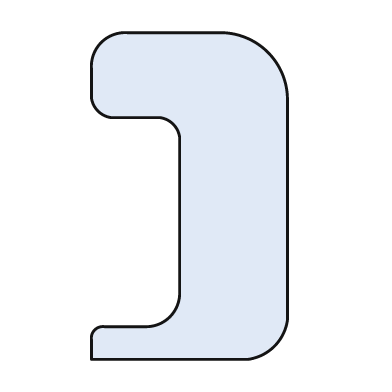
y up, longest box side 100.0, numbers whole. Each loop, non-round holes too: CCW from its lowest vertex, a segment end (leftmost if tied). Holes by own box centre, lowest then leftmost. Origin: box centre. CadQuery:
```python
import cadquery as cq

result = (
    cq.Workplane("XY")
    .moveTo(-30.0, -50.0)
    .lineTo(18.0, -50.0)
    .threePointArc((26.0, -46.0), (30.0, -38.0))
    .lineTo(30.0, 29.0)
    .threePointArc((24.0, 44.0), (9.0, 50.0))
    .lineTo(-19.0, 50.0)
    .threePointArc((-27.0, 47.0), (-30.0, 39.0))
    .lineTo(-30.0, 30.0)
    .threePointArc((-28.0, 26.0), (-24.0, 24.0))
    .lineTo(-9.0, 24.0)
    .threePointArc((-5.0, 22.0), (-3.0, 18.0))
    .lineTo(-3.0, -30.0)
    .threePointArc((-6.0, -37.0), (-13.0, -40.0))
    .lineTo(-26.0, -40.0)
    .threePointArc((-29.0, -41.0), (-30.0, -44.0))
    .close()
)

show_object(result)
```